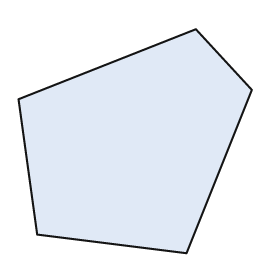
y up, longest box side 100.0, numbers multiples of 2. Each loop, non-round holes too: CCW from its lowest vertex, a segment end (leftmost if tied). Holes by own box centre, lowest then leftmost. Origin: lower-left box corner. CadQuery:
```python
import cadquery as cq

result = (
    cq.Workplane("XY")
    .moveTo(72.0, 0.0)
    .lineTo(100.0, 70.0)
    .lineTo(76.0, 96.0)
    .lineTo(0.0, 66.0)
    .lineTo(8.0, 8.0)
    .close()
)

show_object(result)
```